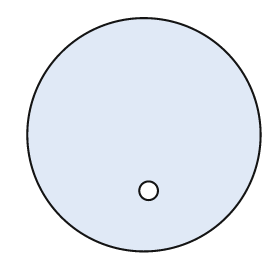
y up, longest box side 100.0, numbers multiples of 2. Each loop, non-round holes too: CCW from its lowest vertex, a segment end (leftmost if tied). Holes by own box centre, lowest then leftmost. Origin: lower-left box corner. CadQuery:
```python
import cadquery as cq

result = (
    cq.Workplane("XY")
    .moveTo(50.0, 50.0)
    .circle(50.0)
    .moveTo(52.0, 26.0)
    .circle(4.0)
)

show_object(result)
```